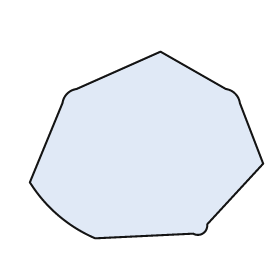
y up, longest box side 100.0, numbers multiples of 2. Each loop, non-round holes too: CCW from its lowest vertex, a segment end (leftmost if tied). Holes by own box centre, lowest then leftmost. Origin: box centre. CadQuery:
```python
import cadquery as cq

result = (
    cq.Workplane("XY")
    .moveTo(-22.0, -40.0)
    .lineTo(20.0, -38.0)
    .threePointArc((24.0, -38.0), (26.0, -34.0))
    .lineTo(50.0, -8.0)
    .lineTo(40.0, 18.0)
    .threePointArc((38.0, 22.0), (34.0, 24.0))
    .lineTo(6.0, 40.0)
    .lineTo(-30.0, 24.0)
    .threePointArc((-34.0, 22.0), (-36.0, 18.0))
    .lineTo(-50.0, -16.0)
    .threePointArc((-38.0, -30.0), (-22.0, -40.0))
    .close()
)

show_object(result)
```